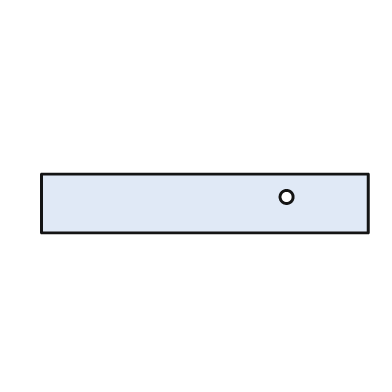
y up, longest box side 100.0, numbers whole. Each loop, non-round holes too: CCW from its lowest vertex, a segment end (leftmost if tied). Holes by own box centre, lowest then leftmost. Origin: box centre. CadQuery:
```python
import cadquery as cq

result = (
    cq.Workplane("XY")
    .moveTo(-50.0, -9.0)
    .lineTo(50.0, -9.0)
    .lineTo(50.0, 9.0)
    .lineTo(-50.0, 9.0)
    .close()
    .moveTo(25.0, 2.0)
    .circle(2.0)
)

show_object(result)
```